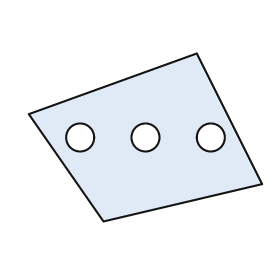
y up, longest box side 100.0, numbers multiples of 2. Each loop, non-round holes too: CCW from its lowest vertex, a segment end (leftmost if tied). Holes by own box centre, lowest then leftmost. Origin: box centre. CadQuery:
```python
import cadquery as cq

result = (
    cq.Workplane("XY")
    .moveTo(-18.0, -36.0)
    .lineTo(50.0, -20.0)
    .lineTo(22.0, 36.0)
    .lineTo(-50.0, 10.0)
    .close()
    .moveTo(-28.0, 0.0)
    .circle(6.0)
    .moveTo(0.0, 0.0)
    .circle(6.0)
    .moveTo(28.0, 0.0)
    .circle(6.0)
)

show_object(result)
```